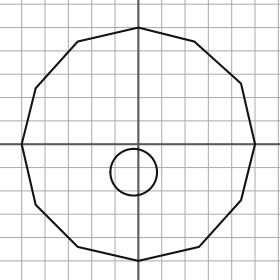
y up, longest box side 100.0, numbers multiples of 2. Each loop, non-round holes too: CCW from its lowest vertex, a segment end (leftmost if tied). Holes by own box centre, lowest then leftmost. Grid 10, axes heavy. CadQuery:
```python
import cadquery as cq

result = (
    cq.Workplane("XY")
    .moveTo(0.0, -50.0)
    .lineTo(26.0, -44.0)
    .lineTo(44.0, -24.0)
    .lineTo(50.0, 0.0)
    .lineTo(44.0, 26.0)
    .lineTo(24.0, 44.0)
    .lineTo(0.0, 50.0)
    .lineTo(-26.0, 44.0)
    .lineTo(-44.0, 24.0)
    .lineTo(-50.0, 0.0)
    .lineTo(-44.0, -26.0)
    .lineTo(-26.0, -44.0)
    .close()
    .moveTo(-2.0, -12.0)
    .circle(10.0)
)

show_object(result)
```